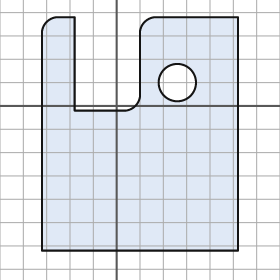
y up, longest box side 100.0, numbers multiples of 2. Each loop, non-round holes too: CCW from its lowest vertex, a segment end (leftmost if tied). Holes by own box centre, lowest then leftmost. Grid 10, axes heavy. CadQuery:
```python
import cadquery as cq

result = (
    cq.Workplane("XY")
    .moveTo(-32.0, -62.0)
    .lineTo(52.0, -62.0)
    .lineTo(52.0, 38.0)
    .lineTo(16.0, 38.0)
    .threePointArc((12.0, 36.0), (10.0, 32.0))
    .lineTo(10.0, 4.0)
    .threePointArc((8.0, 0.0), (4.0, -2.0))
    .lineTo(-18.0, -2.0)
    .lineTo(-18.0, 38.0)
    .lineTo(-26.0, 38.0)
    .threePointArc((-30.0, 36.0), (-32.0, 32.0))
    .close()
    .moveTo(26.0, 10.0)
    .circle(8.0)
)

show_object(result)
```